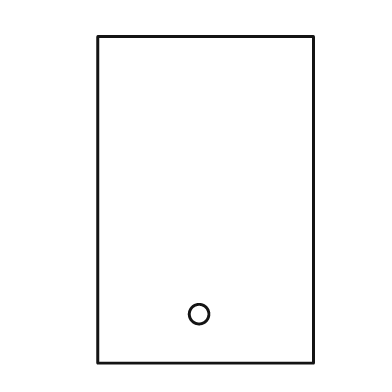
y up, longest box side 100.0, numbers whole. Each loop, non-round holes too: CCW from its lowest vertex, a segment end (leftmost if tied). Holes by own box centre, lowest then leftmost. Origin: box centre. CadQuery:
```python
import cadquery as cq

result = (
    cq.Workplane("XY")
    .moveTo(-33.0, -50.0)
    .lineTo(33.0, -50.0)
    .lineTo(33.0, 50.0)
    .lineTo(-33.0, 50.0)
    .close()
    .moveTo(-2.0, -35.0)
    .circle(3.0)
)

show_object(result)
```